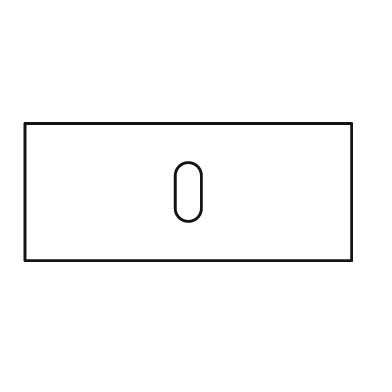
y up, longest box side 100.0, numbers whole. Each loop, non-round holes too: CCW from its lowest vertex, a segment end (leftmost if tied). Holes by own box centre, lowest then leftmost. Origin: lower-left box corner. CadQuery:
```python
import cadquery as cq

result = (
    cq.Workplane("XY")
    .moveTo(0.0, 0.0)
    .lineTo(100.0, 0.0)
    .lineTo(100.0, 42.0)
    .lineTo(0.0, 42.0)
    .close()
    .moveTo(46.0, 16.0)
    .threePointArc((50.0, 12.0), (54.0, 16.0))
    .lineTo(54.0, 26.0)
    .threePointArc((50.0, 30.0), (46.0, 26.0))
    .close()
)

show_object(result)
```